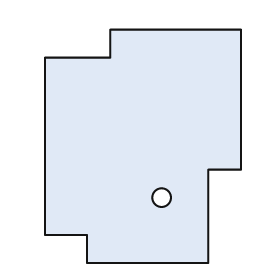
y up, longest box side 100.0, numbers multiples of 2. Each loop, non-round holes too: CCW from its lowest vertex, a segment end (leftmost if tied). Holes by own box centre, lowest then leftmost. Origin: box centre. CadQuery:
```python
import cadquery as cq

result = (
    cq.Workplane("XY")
    .moveTo(-24.0, -50.0)
    .lineTo(28.0, -50.0)
    .lineTo(28.0, -10.0)
    .lineTo(42.0, -10.0)
    .lineTo(42.0, 50.0)
    .lineTo(-14.0, 50.0)
    .lineTo(-14.0, 38.0)
    .lineTo(-42.0, 38.0)
    .lineTo(-42.0, -38.0)
    .lineTo(-24.0, -38.0)
    .close()
    .moveTo(8.0, -22.0)
    .circle(4.0)
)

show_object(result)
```